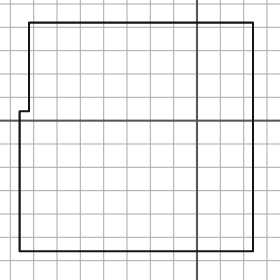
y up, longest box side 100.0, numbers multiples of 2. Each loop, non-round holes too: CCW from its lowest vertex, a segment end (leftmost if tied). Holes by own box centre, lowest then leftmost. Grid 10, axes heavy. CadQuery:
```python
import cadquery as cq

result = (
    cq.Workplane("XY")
    .moveTo(-76.0, -56.0)
    .lineTo(24.0, -56.0)
    .lineTo(24.0, 42.0)
    .lineTo(-72.0, 42.0)
    .lineTo(-72.0, 4.0)
    .lineTo(-76.0, 4.0)
    .close()
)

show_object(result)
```